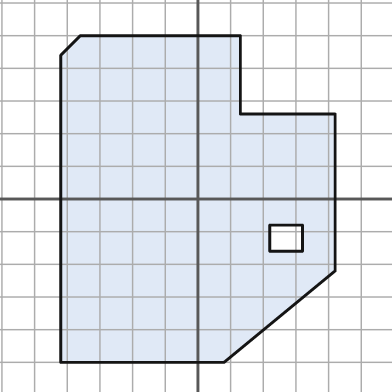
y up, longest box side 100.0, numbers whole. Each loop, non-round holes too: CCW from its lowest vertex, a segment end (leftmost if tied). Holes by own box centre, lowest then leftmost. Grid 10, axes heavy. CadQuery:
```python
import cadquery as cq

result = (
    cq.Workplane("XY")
    .moveTo(-42.0, -50.0)
    .lineTo(8.0, -50.0)
    .lineTo(42.0, -22.0)
    .lineTo(42.0, 26.0)
    .lineTo(13.0, 26.0)
    .lineTo(13.0, 50.0)
    .lineTo(-36.0, 50.0)
    .lineTo(-42.0, 44.0)
    .close()
    .moveTo(22.0, -16.0)
    .lineTo(32.0, -16.0)
    .lineTo(32.0, -8.0)
    .lineTo(22.0, -8.0)
    .close()
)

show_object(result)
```